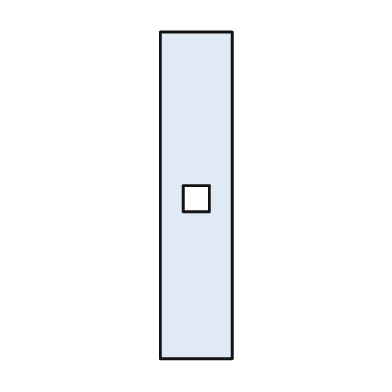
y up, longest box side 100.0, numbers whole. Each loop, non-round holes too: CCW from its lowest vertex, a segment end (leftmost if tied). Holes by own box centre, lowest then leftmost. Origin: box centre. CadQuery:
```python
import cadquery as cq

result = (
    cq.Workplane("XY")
    .moveTo(-11.0, -50.0)
    .lineTo(11.0, -50.0)
    .lineTo(11.0, 50.0)
    .lineTo(-11.0, 50.0)
    .close()
    .moveTo(-4.0, -5.0)
    .lineTo(4.0, -5.0)
    .lineTo(4.0, 3.0)
    .lineTo(-4.0, 3.0)
    .close()
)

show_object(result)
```